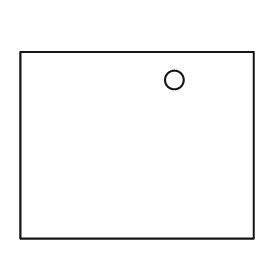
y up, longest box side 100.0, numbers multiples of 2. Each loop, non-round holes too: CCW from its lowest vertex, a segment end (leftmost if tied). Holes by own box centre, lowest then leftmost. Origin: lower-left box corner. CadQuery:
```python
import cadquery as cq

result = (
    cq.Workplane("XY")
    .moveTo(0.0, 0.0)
    .lineTo(100.0, 0.0)
    .lineTo(100.0, 80.0)
    .lineTo(0.0, 80.0)
    .close()
    .moveTo(66.0, 68.0)
    .circle(4.0)
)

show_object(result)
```